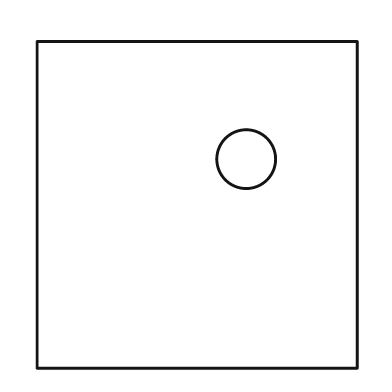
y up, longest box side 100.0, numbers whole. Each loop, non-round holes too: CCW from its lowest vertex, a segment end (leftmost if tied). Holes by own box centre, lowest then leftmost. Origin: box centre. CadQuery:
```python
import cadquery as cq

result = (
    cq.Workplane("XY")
    .moveTo(-49.0, -50.0)
    .lineTo(49.0, -50.0)
    .lineTo(49.0, 50.0)
    .lineTo(-49.0, 50.0)
    .close()
    .moveTo(15.0, 14.0)
    .circle(9.0)
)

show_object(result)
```